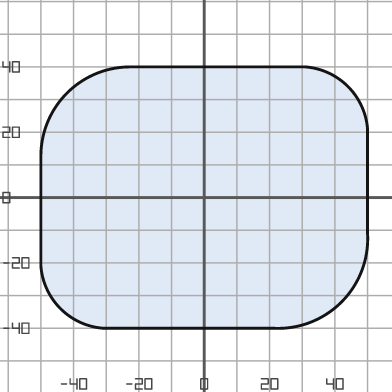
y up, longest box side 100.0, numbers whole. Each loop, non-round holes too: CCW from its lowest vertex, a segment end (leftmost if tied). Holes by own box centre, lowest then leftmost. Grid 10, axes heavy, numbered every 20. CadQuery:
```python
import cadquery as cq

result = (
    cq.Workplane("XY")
    .moveTo(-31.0, -40.0)
    .lineTo(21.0, -40.0)
    .threePointArc((42.0, -32.0), (50.0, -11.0))
    .lineTo(50.0, 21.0)
    .threePointArc((44.0, 34.0), (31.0, 40.0))
    .lineTo(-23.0, 40.0)
    .threePointArc((-42.0, 32.0), (-50.0, 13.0))
    .lineTo(-50.0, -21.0)
    .threePointArc((-44.0, -34.0), (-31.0, -40.0))
    .close()
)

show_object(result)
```